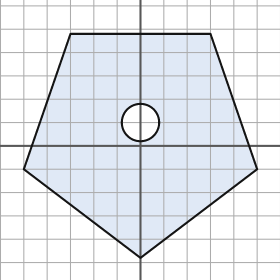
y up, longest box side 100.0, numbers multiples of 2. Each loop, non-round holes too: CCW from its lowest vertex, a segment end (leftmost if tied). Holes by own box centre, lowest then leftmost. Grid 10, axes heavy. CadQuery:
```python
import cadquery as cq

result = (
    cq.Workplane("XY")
    .moveTo(0.0, -48.0)
    .lineTo(50.0, -10.0)
    .lineTo(30.0, 48.0)
    .lineTo(-30.0, 48.0)
    .lineTo(-50.0, -10.0)
    .close()
    .moveTo(0.0, 10.0)
    .circle(8.0)
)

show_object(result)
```